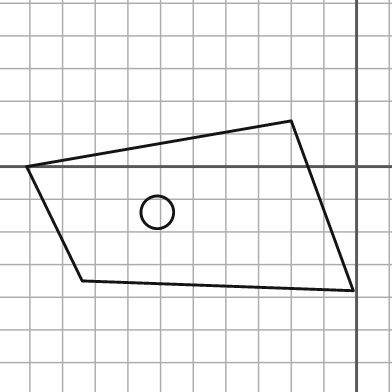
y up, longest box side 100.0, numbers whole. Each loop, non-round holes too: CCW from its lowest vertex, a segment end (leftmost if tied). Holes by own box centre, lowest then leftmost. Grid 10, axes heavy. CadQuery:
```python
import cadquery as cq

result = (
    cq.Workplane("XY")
    .moveTo(-1.0, -38.0)
    .lineTo(-20.0, 14.0)
    .lineTo(-101.0, 0.0)
    .lineTo(-84.0, -35.0)
    .close()
    .moveTo(-61.0, -14.0)
    .circle(5.0)
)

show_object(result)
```